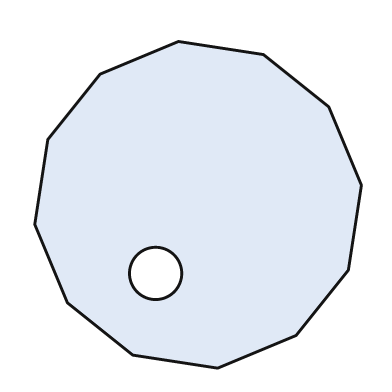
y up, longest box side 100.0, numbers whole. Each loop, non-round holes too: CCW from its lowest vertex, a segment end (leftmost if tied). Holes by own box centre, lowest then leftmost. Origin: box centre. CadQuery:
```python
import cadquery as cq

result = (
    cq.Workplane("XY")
    .moveTo(6.0, -50.0)
    .lineTo(30.0, -40.0)
    .lineTo(46.0, -20.0)
    .lineTo(50.0, 6.0)
    .lineTo(40.0, 30.0)
    .lineTo(20.0, 46.0)
    .lineTo(-6.0, 50.0)
    .lineTo(-30.0, 40.0)
    .lineTo(-46.0, 20.0)
    .lineTo(-50.0, -6.0)
    .lineTo(-40.0, -30.0)
    .lineTo(-20.0, -46.0)
    .close()
    .moveTo(-13.0, -21.0)
    .circle(8.0)
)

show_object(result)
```